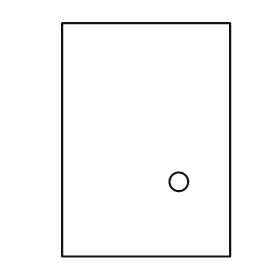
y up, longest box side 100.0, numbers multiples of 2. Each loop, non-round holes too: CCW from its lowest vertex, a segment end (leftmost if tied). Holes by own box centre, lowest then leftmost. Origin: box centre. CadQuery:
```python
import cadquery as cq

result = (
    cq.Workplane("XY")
    .moveTo(-36.0, -50.0)
    .lineTo(36.0, -50.0)
    .lineTo(36.0, 50.0)
    .lineTo(-36.0, 50.0)
    .close()
    .moveTo(14.0, -18.0)
    .circle(4.0)
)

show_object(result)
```